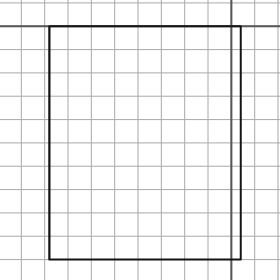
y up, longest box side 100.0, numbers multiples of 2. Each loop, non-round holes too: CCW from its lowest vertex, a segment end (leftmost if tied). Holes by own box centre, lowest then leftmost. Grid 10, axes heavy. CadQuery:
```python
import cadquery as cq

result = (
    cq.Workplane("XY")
    .moveTo(-78.0, -100.0)
    .lineTo(4.0, -100.0)
    .lineTo(4.0, 0.0)
    .lineTo(-78.0, 0.0)
    .close()
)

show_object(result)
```